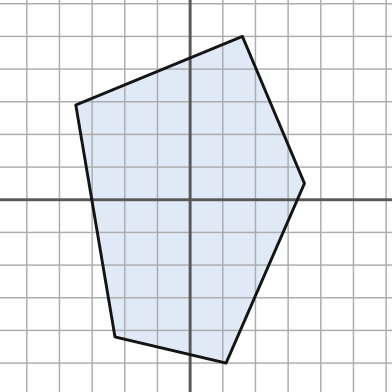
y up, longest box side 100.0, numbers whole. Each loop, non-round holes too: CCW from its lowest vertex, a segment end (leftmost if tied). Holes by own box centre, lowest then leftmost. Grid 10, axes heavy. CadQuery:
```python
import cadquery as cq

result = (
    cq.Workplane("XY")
    .moveTo(11.0, -50.0)
    .lineTo(35.0, 5.0)
    .lineTo(16.0, 50.0)
    .lineTo(-35.0, 29.0)
    .lineTo(-23.0, -42.0)
    .close()
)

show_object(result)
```